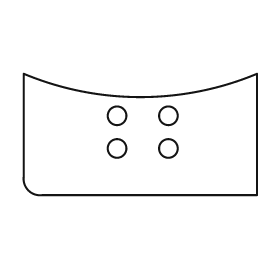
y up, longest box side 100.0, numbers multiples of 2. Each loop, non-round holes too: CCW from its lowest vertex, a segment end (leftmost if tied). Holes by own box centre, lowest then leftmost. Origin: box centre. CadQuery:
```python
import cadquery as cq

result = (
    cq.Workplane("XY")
    .moveTo(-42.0, -26.0)
    .lineTo(50.0, -26.0)
    .lineTo(50.0, 26.0)
    .threePointArc((0.0, 16.0), (-50.0, 26.0))
    .lineTo(-50.0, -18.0)
    .threePointArc((-48.0, -24.0), (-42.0, -26.0))
    .close()
    .moveTo(-10.0, -6.0)
    .circle(4.0)
    .moveTo(12.0, -6.0)
    .circle(4.0)
    .moveTo(-10.0, 8.0)
    .circle(4.0)
    .moveTo(12.0, 8.0)
    .circle(4.0)
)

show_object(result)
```